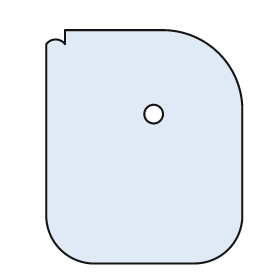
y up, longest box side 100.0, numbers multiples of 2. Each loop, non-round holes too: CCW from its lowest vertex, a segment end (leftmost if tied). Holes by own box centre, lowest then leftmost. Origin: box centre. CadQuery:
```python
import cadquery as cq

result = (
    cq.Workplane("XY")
    .moveTo(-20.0, -50.0)
    .lineTo(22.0, -50.0)
    .threePointArc((36.0, -44.0), (42.0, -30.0))
    .lineTo(42.0, 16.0)
    .threePointArc((32.0, 40.0), (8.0, 50.0))
    .lineTo(-34.0, 50.0)
    .lineTo(-34.0, 44.0)
    .threePointArc((-38.0, 46.0), (-42.0, 44.0))
    .lineTo(-42.0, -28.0)
    .threePointArc((-36.0, -44.0), (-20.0, -50.0))
    .close()
    .moveTo(4.0, 14.0)
    .circle(4.0)
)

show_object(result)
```